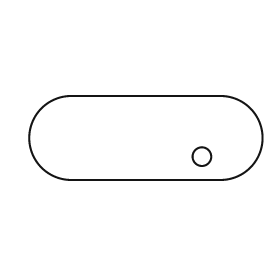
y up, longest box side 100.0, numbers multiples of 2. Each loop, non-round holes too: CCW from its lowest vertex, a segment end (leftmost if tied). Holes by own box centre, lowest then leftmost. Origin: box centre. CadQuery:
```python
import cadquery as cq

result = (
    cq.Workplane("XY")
    .moveTo(-32.0, -18.0)
    .lineTo(32.0, -18.0)
    .threePointArc((50.0, 0.0), (32.0, 18.0))
    .lineTo(-32.0, 18.0)
    .threePointArc((-50.0, 0.0), (-32.0, -18.0))
    .close()
    .moveTo(24.0, -8.0)
    .circle(4.0)
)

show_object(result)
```